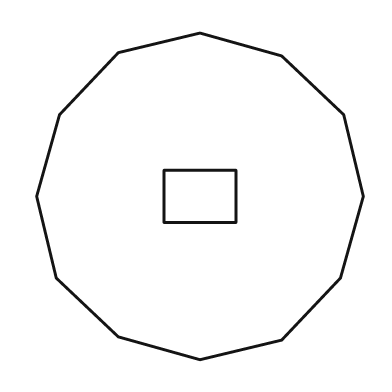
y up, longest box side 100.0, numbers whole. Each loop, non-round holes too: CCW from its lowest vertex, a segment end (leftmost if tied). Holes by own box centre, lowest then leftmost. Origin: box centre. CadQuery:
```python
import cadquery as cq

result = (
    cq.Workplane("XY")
    .moveTo(0.0, -50.0)
    .lineTo(25.0, -44.0)
    .lineTo(43.0, -25.0)
    .lineTo(50.0, 0.0)
    .lineTo(44.0, 25.0)
    .lineTo(25.0, 43.0)
    .lineTo(0.0, 50.0)
    .lineTo(-25.0, 44.0)
    .lineTo(-43.0, 25.0)
    .lineTo(-50.0, 0.0)
    .lineTo(-44.0, -25.0)
    .lineTo(-25.0, -43.0)
    .close()
    .moveTo(-11.0, -8.0)
    .lineTo(11.0, -8.0)
    .lineTo(11.0, 8.0)
    .lineTo(-11.0, 8.0)
    .close()
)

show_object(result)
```